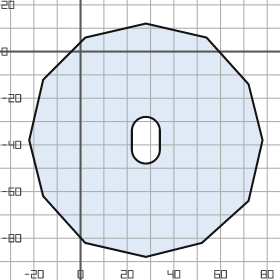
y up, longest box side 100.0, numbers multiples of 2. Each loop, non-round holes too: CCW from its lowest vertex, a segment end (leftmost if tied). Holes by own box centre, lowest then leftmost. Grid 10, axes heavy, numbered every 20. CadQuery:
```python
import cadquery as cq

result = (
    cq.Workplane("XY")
    .moveTo(28.0, -88.0)
    .lineTo(52.0, -82.0)
    .lineTo(72.0, -64.0)
    .lineTo(78.0, -38.0)
    .lineTo(72.0, -14.0)
    .lineTo(54.0, 6.0)
    .lineTo(28.0, 12.0)
    .lineTo(2.0, 6.0)
    .lineTo(-16.0, -12.0)
    .lineTo(-22.0, -38.0)
    .lineTo(-16.0, -62.0)
    .lineTo(2.0, -82.0)
    .close()
    .moveTo(22.0, -42.0)
    .threePointArc((28.0, -48.0), (34.0, -42.0))
    .lineTo(34.0, -34.0)
    .threePointArc((28.0, -28.0), (22.0, -34.0))
    .close()
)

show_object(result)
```